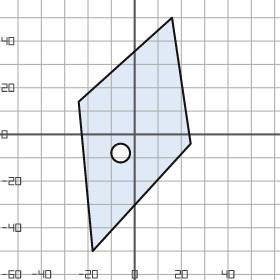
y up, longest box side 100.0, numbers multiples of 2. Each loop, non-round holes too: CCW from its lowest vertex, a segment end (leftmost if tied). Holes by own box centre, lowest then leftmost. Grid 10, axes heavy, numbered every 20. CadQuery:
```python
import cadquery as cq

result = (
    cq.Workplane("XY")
    .moveTo(-18.0, -50.0)
    .lineTo(24.0, -4.0)
    .lineTo(16.0, 50.0)
    .lineTo(-24.0, 14.0)
    .close()
    .moveTo(-6.0, -8.0)
    .circle(4.0)
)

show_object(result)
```